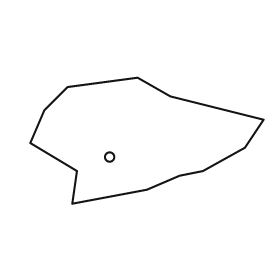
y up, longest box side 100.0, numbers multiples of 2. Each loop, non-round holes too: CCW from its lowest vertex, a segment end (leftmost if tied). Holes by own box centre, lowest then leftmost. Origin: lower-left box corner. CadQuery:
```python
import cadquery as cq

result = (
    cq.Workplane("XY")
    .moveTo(18.0, 0.0)
    .lineTo(50.0, 6.0)
    .lineTo(64.0, 12.0)
    .lineTo(74.0, 14.0)
    .lineTo(92.0, 24.0)
    .lineTo(100.0, 36.0)
    .lineTo(60.0, 46.0)
    .lineTo(46.0, 54.0)
    .lineTo(16.0, 50.0)
    .lineTo(6.0, 40.0)
    .lineTo(0.0, 26.0)
    .lineTo(20.0, 14.0)
    .close()
    .moveTo(34.0, 20.0)
    .circle(2.0)
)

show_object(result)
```